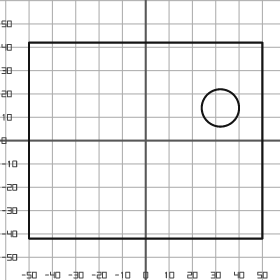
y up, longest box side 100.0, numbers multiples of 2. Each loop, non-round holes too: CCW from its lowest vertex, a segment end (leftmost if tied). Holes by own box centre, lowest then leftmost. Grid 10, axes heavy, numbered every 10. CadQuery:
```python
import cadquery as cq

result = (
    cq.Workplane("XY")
    .moveTo(-50.0, -42.0)
    .lineTo(50.0, -42.0)
    .lineTo(50.0, 42.0)
    .lineTo(-50.0, 42.0)
    .close()
    .moveTo(32.0, 14.0)
    .circle(8.0)
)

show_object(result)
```